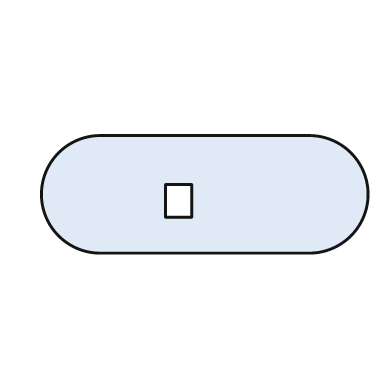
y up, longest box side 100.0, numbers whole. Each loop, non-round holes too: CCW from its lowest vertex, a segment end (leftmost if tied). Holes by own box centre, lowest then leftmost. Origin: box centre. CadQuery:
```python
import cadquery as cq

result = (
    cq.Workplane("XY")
    .moveTo(-32.0, -18.0)
    .lineTo(32.0, -18.0)
    .threePointArc((50.0, 0.0), (32.0, 18.0))
    .lineTo(-32.0, 18.0)
    .threePointArc((-50.0, 0.0), (-32.0, -18.0))
    .close()
    .moveTo(-12.0, -7.0)
    .lineTo(-4.0, -7.0)
    .lineTo(-4.0, 3.0)
    .lineTo(-12.0, 3.0)
    .close()
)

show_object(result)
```